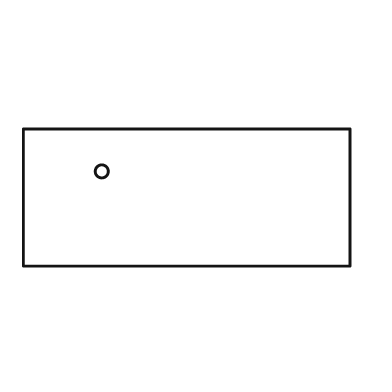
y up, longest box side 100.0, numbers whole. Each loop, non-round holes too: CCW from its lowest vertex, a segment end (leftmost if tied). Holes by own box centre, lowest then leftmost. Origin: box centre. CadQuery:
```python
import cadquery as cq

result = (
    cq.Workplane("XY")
    .moveTo(-50.0, -21.0)
    .lineTo(50.0, -21.0)
    .lineTo(50.0, 21.0)
    .lineTo(-50.0, 21.0)
    .close()
    .moveTo(-26.0, 8.0)
    .circle(2.0)
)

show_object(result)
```